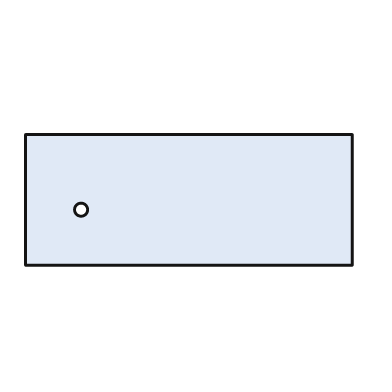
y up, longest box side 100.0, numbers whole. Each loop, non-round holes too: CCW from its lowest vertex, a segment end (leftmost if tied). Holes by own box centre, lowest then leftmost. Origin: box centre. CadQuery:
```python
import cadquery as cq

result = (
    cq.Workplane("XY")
    .moveTo(-50.0, -20.0)
    .lineTo(50.0, -20.0)
    .lineTo(50.0, 20.0)
    .lineTo(-50.0, 20.0)
    .close()
    .moveTo(-33.0, -3.0)
    .circle(2.0)
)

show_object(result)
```